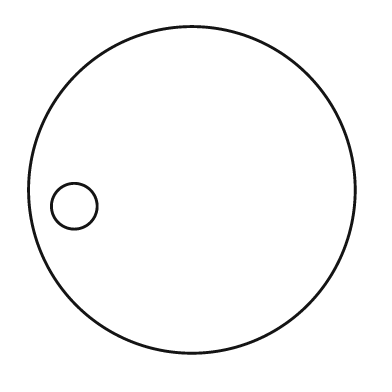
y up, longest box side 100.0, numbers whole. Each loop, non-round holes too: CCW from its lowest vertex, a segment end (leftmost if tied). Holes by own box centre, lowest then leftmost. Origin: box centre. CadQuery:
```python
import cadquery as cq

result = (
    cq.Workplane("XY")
    .moveTo(0.0, 0.0)
    .circle(50.0)
    .moveTo(-36.0, -5.0)
    .circle(7.0)
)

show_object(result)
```